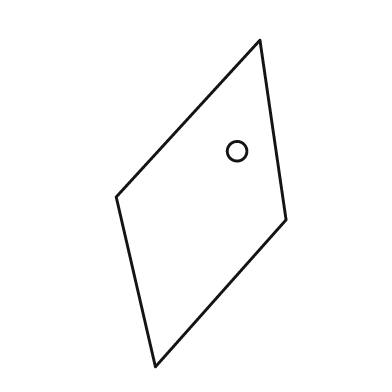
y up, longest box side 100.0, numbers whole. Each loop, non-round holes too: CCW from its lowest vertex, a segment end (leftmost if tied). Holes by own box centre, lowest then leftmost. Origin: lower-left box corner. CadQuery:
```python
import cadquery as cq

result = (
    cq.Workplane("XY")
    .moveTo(12.0, 0.0)
    .lineTo(52.0, 45.0)
    .lineTo(44.0, 100.0)
    .lineTo(0.0, 52.0)
    .close()
    .moveTo(37.0, 66.0)
    .circle(3.0)
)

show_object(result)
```